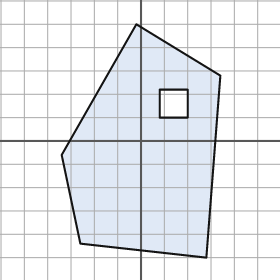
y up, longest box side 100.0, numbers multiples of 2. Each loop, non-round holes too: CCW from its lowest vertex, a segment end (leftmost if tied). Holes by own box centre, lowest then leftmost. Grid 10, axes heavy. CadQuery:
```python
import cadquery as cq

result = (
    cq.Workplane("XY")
    .moveTo(28.0, -50.0)
    .lineTo(34.0, 28.0)
    .lineTo(-2.0, 50.0)
    .lineTo(-34.0, -6.0)
    .lineTo(-26.0, -44.0)
    .close()
    .moveTo(8.0, 10.0)
    .lineTo(20.0, 10.0)
    .lineTo(20.0, 22.0)
    .lineTo(8.0, 22.0)
    .close()
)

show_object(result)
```